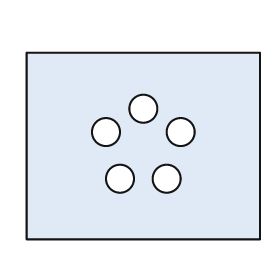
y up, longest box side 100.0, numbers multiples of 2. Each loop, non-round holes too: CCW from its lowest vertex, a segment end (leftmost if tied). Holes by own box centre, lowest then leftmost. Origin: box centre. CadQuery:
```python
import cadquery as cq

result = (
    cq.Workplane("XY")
    .moveTo(-50.0, -40.0)
    .lineTo(50.0, -40.0)
    .lineTo(50.0, 40.0)
    .lineTo(-50.0, 40.0)
    .close()
    .moveTo(-10.0, -14.0)
    .circle(6.0)
    .moveTo(10.0, -14.0)
    .circle(6.0)
    .moveTo(-16.0, 6.0)
    .circle(6.0)
    .moveTo(16.0, 6.0)
    .circle(6.0)
    .moveTo(0.0, 16.0)
    .circle(6.0)
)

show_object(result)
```